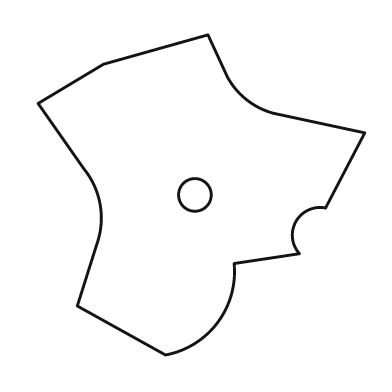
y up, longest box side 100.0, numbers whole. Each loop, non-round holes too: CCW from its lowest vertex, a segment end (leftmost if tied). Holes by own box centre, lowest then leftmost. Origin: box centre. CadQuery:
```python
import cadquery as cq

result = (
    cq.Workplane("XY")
    .moveTo(-11.0, -49.0)
    .threePointArc((5.0, -39.0), (10.0, -21.0))
    .lineTo(30.0, -18.0)
    .threePointArc((29.0, -8.0), (38.0, -4.0))
    .lineTo(50.0, 19.0)
    .lineTo(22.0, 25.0)
    .threePointArc((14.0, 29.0), (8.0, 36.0))
    .lineTo(2.0, 49.0)
    .lineTo(-30.0, 40.0)
    .lineTo(-50.0, 28.0)
    .lineTo(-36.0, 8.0)
    .threePointArc((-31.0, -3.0), (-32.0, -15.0))
    .lineTo(-38.0, -34.0)
    .close()
    .moveTo(-2.0, 0.0)
    .circle(5.0)
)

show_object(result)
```